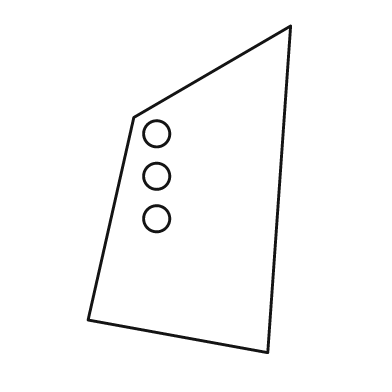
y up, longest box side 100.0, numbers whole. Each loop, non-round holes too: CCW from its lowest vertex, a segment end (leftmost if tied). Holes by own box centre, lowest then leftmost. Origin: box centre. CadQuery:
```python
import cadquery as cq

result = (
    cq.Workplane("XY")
    .moveTo(24.0, -50.0)
    .lineTo(31.0, 50.0)
    .lineTo(-17.0, 22.0)
    .lineTo(-31.0, -40.0)
    .close()
    .moveTo(-10.0, -9.0)
    .circle(4.0)
    .moveTo(-10.0, 4.0)
    .circle(4.0)
    .moveTo(-10.0, 17.0)
    .circle(4.0)
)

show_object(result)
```